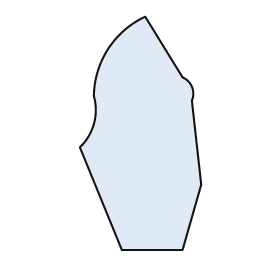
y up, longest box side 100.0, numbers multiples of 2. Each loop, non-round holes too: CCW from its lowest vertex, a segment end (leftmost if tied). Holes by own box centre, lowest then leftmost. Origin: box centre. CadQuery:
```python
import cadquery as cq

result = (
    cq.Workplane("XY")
    .moveTo(-8.0, -50.0)
    .lineTo(18.0, -50.0)
    .lineTo(26.0, -22.0)
    .lineTo(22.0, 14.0)
    .threePointArc((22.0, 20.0), (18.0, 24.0))
    .lineTo(2.0, 50.0)
    .threePointArc((-14.0, 36.0), (-20.0, 16.0))
    .threePointArc((-20.0, 4.0), (-26.0, -6.0))
    .close()
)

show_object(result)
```